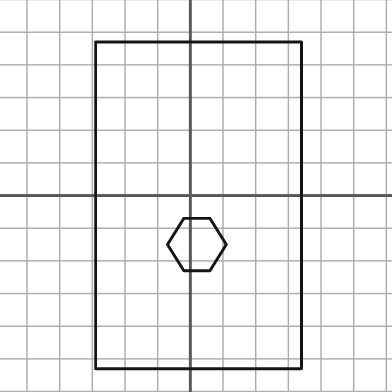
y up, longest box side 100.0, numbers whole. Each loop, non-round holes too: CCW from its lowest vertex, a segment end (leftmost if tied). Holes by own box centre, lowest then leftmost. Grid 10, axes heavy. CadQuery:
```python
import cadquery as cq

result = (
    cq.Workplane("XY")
    .moveTo(-29.0, -53.0)
    .lineTo(34.0, -53.0)
    .lineTo(34.0, 47.0)
    .lineTo(-29.0, 47.0)
    .close()
    .moveTo(-2.0, -23.0)
    .lineTo(6.0, -23.0)
    .lineTo(11.0, -15.0)
    .lineTo(6.0, -7.0)
    .lineTo(-2.0, -7.0)
    .lineTo(-7.0, -15.0)
    .close()
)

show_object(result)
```